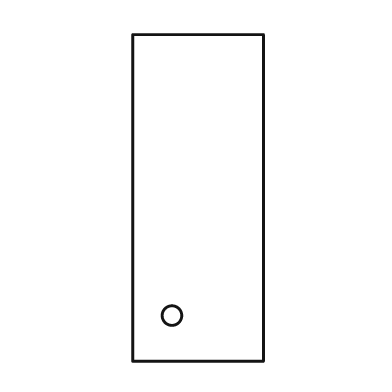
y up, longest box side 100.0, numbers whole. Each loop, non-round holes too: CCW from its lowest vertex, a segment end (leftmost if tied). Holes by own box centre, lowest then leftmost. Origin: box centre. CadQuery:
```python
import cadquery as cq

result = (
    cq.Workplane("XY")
    .moveTo(-20.0, -50.0)
    .lineTo(20.0, -50.0)
    .lineTo(20.0, 50.0)
    .lineTo(-20.0, 50.0)
    .close()
    .moveTo(-8.0, -36.0)
    .circle(3.0)
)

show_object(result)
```